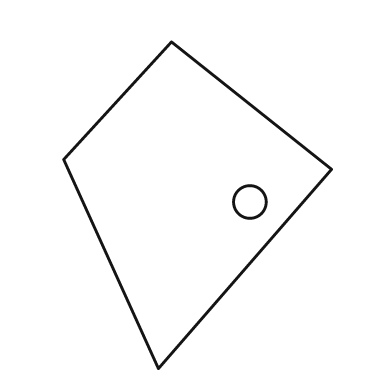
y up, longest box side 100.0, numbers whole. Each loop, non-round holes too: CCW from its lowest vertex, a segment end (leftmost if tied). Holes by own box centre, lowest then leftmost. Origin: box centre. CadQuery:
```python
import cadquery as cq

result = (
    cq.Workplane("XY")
    .moveTo(-12.0, -50.0)
    .lineTo(41.0, 11.0)
    .lineTo(-8.0, 50.0)
    .lineTo(-41.0, 14.0)
    .close()
    .moveTo(16.0, 1.0)
    .circle(5.0)
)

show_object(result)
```